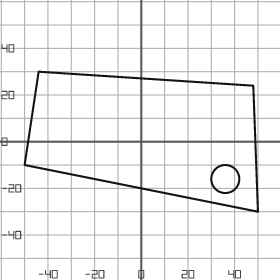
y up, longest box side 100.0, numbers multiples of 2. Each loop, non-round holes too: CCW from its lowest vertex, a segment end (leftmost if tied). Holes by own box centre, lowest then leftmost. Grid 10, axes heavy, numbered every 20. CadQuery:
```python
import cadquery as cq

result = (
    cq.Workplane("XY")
    .moveTo(50.0, -30.0)
    .lineTo(48.0, 24.0)
    .lineTo(-44.0, 30.0)
    .lineTo(-50.0, -10.0)
    .close()
    .moveTo(36.0, -16.0)
    .circle(6.0)
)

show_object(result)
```